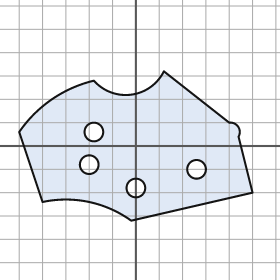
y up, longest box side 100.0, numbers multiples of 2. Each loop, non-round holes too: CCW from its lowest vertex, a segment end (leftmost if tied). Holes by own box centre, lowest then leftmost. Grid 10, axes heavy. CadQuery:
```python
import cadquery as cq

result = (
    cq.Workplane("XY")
    .moveTo(-2.0, -32.0)
    .lineTo(50.0, -20.0)
    .lineTo(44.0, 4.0)
    .threePointArc((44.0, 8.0), (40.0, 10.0))
    .lineTo(12.0, 32.0)
    .threePointArc((-2.0, 22.0), (-18.0, 28.0))
    .threePointArc((-36.0, 20.0), (-50.0, 6.0))
    .lineTo(-40.0, -24.0)
    .threePointArc((-20.0, -24.0), (-2.0, -32.0))
    .close()
    .moveTo(0.0, -18.0)
    .circle(4.0)
    .moveTo(26.0, -10.0)
    .circle(4.0)
    .moveTo(-20.0, -8.0)
    .circle(4.0)
    .moveTo(-18.0, 6.0)
    .circle(4.0)
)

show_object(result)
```